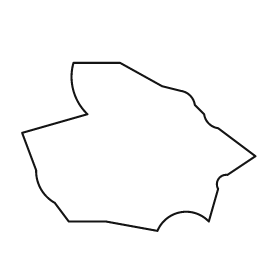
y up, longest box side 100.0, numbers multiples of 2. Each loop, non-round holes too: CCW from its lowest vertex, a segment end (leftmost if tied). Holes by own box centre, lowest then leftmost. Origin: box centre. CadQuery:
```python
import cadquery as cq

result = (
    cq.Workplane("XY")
    .moveTo(8.0, -36.0)
    .threePointArc((18.0, -28.0), (30.0, -32.0))
    .lineTo(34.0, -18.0)
    .threePointArc((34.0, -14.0), (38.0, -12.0))
    .lineTo(50.0, -4.0)
    .lineTo(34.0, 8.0)
    .threePointArc((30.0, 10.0), (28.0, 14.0))
    .lineTo(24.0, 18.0)
    .threePointArc((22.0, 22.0), (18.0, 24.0))
    .lineTo(10.0, 26.0)
    .lineTo(-8.0, 36.0)
    .lineTo(-28.0, 36.0)
    .threePointArc((-28.0, 24.0), (-22.0, 14.0))
    .lineTo(-50.0, 6.0)
    .lineTo(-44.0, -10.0)
    .threePointArc((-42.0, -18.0), (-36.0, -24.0))
    .lineTo(-30.0, -32.0)
    .lineTo(-14.0, -32.0)
    .close()
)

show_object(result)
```